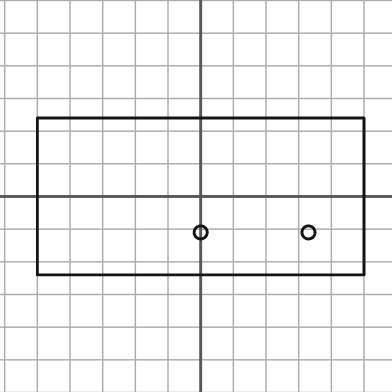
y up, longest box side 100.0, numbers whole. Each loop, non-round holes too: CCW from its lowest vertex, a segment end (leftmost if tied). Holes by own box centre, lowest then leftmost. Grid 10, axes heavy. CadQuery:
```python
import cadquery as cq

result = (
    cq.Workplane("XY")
    .moveTo(-50.0, -24.0)
    .lineTo(50.0, -24.0)
    .lineTo(50.0, 24.0)
    .lineTo(-50.0, 24.0)
    .close()
    .moveTo(0.0, -11.0)
    .circle(2.0)
    .moveTo(33.0, -11.0)
    .circle(2.0)
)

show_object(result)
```